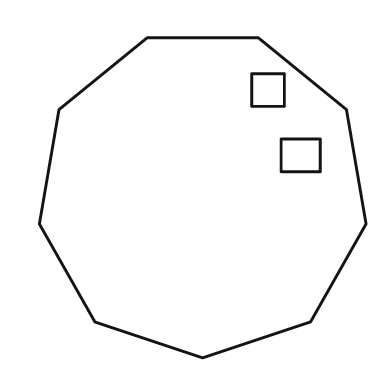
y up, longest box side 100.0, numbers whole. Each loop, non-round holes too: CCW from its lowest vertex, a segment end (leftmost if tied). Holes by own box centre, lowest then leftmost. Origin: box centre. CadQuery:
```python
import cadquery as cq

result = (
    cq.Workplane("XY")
    .moveTo(0.0, -49.0)
    .lineTo(33.0, -38.0)
    .lineTo(50.0, -8.0)
    .lineTo(44.0, 27.0)
    .lineTo(17.0, 49.0)
    .lineTo(-17.0, 49.0)
    .lineTo(-44.0, 27.0)
    .lineTo(-50.0, -8.0)
    .lineTo(-33.0, -38.0)
    .close()
    .moveTo(24.0, 8.0)
    .lineTo(36.0, 8.0)
    .lineTo(36.0, 18.0)
    .lineTo(24.0, 18.0)
    .close()
    .moveTo(15.0, 28.0)
    .lineTo(25.0, 28.0)
    .lineTo(25.0, 38.0)
    .lineTo(15.0, 38.0)
    .close()
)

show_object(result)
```